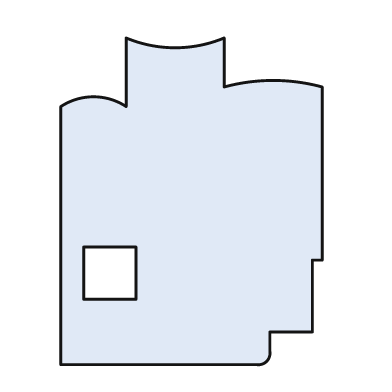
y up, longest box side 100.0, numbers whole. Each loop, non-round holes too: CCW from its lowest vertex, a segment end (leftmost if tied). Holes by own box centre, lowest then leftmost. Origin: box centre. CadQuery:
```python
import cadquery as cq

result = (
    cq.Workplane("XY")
    .moveTo(-40.0, -50.0)
    .lineTo(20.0, -50.0)
    .threePointArc((23.0, -49.0), (24.0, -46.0))
    .lineTo(24.0, -40.0)
    .lineTo(37.0, -40.0)
    .lineTo(37.0, -18.0)
    .lineTo(40.0, -18.0)
    .lineTo(40.0, 35.0)
    .threePointArc((25.0, 37.0), (10.0, 35.0))
    .lineTo(10.0, 50.0)
    .threePointArc((-5.0, 47.0), (-20.0, 50.0))
    .lineTo(-20.0, 29.0)
    .threePointArc((-30.0, 32.0), (-40.0, 29.0))
    .close()
    .moveTo(-33.0, -30.0)
    .lineTo(-17.0, -30.0)
    .lineTo(-17.0, -14.0)
    .lineTo(-33.0, -14.0)
    .close()
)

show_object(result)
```